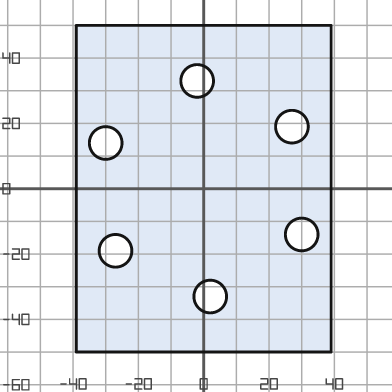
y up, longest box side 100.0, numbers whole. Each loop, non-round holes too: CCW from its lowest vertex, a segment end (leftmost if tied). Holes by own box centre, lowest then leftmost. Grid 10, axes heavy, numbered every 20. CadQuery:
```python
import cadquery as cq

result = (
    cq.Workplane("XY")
    .moveTo(-39.0, -50.0)
    .lineTo(39.0, -50.0)
    .lineTo(39.0, 50.0)
    .lineTo(-39.0, 50.0)
    .close()
    .moveTo(2.0, -33.0)
    .circle(5.0)
    .moveTo(-27.0, -19.0)
    .circle(5.0)
    .moveTo(30.0, -14.0)
    .circle(5.0)
    .moveTo(-30.0, 14.0)
    .circle(5.0)
    .moveTo(27.0, 19.0)
    .circle(5.0)
    .moveTo(-2.0, 33.0)
    .circle(5.0)
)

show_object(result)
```